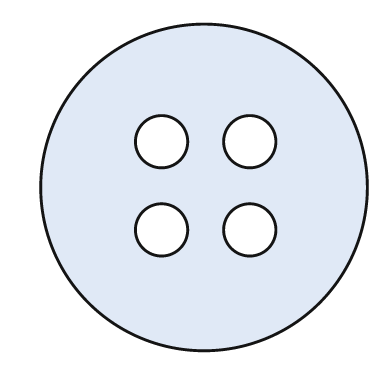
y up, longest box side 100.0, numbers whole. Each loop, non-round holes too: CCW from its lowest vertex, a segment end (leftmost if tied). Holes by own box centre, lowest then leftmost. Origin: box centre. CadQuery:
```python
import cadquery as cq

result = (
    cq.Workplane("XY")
    .moveTo(0.0, 0.0)
    .circle(50.0)
    .moveTo(-13.0, -13.0)
    .circle(8.0)
    .moveTo(14.0, -13.0)
    .circle(8.0)
    .moveTo(-13.0, 14.0)
    .circle(8.0)
    .moveTo(14.0, 14.0)
    .circle(8.0)
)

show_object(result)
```